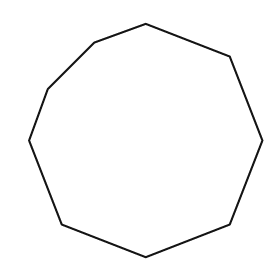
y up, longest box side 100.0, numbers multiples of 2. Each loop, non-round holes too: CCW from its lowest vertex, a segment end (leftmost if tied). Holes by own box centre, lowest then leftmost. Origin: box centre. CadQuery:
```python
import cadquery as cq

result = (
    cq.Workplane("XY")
    .moveTo(0.0, -50.0)
    .lineTo(36.0, -36.0)
    .lineTo(50.0, 0.0)
    .lineTo(36.0, 36.0)
    .lineTo(0.0, 50.0)
    .lineTo(-22.0, 42.0)
    .lineTo(-42.0, 22.0)
    .lineTo(-50.0, 0.0)
    .lineTo(-36.0, -36.0)
    .close()
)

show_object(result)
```